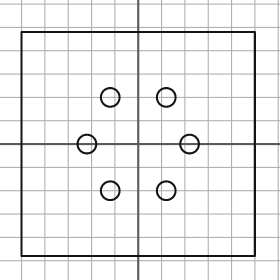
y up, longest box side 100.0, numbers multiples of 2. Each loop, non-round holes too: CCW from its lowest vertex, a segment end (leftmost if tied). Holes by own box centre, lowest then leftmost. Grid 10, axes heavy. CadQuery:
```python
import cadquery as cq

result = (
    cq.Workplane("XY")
    .moveTo(-50.0, -48.0)
    .lineTo(50.0, -48.0)
    .lineTo(50.0, 48.0)
    .lineTo(-50.0, 48.0)
    .close()
    .moveTo(-12.0, -20.0)
    .circle(4.0)
    .moveTo(12.0, -20.0)
    .circle(4.0)
    .moveTo(-22.0, 0.0)
    .circle(4.0)
    .moveTo(22.0, 0.0)
    .circle(4.0)
    .moveTo(-12.0, 20.0)
    .circle(4.0)
    .moveTo(12.0, 20.0)
    .circle(4.0)
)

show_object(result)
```